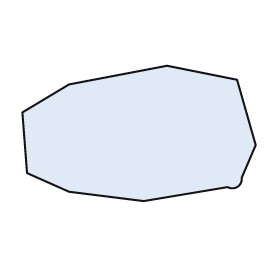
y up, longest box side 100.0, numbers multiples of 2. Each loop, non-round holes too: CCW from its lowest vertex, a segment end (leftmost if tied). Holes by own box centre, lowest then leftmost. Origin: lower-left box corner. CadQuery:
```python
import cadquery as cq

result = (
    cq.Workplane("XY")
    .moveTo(52.0, 0.0)
    .lineTo(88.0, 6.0)
    .threePointArc((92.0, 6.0), (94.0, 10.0))
    .lineTo(100.0, 24.0)
    .lineTo(92.0, 52.0)
    .lineTo(62.0, 58.0)
    .lineTo(20.0, 50.0)
    .lineTo(0.0, 38.0)
    .lineTo(2.0, 12.0)
    .lineTo(20.0, 4.0)
    .close()
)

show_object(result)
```